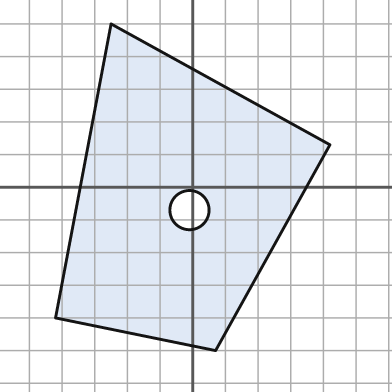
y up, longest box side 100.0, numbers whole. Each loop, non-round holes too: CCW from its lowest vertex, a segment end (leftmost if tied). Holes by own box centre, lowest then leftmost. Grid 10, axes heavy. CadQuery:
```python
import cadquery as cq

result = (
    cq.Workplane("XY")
    .moveTo(7.0, -50.0)
    .lineTo(42.0, 13.0)
    .lineTo(-25.0, 50.0)
    .lineTo(-42.0, -40.0)
    .close()
    .moveTo(-1.0, -7.0)
    .circle(6.0)
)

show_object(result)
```